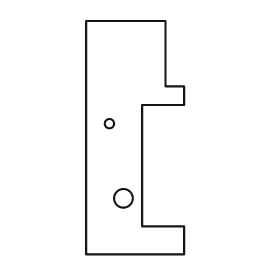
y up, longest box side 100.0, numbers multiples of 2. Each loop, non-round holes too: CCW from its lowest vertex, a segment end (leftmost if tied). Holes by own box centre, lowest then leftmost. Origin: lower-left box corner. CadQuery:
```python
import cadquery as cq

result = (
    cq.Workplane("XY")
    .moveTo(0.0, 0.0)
    .lineTo(42.0, 0.0)
    .lineTo(42.0, 12.0)
    .lineTo(24.0, 12.0)
    .lineTo(24.0, 64.0)
    .lineTo(42.0, 64.0)
    .lineTo(42.0, 72.0)
    .lineTo(34.0, 72.0)
    .lineTo(34.0, 100.0)
    .lineTo(0.0, 100.0)
    .close()
    .moveTo(16.0, 24.0)
    .circle(4.0)
    .moveTo(10.0, 56.0)
    .circle(2.0)
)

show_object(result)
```